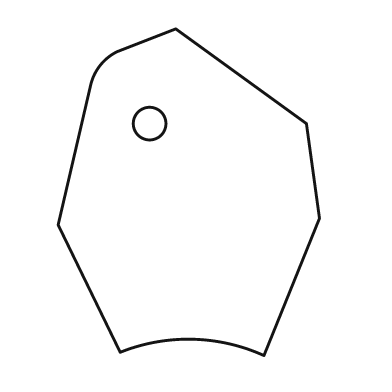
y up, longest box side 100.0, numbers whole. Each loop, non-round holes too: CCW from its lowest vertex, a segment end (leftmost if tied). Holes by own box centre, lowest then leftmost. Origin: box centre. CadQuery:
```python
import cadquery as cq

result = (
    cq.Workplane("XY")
    .moveTo(23.0, -50.0)
    .lineTo(40.0, -8.0)
    .lineTo(36.0, 21.0)
    .lineTo(-4.0, 50.0)
    .lineTo(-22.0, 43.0)
    .threePointArc((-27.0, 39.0), (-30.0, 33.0))
    .lineTo(-40.0, -10.0)
    .lineTo(-21.0, -49.0)
    .threePointArc((1.0, -45.0), (23.0, -50.0))
    .close()
    .moveTo(-12.0, 21.0)
    .circle(5.0)
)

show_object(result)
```